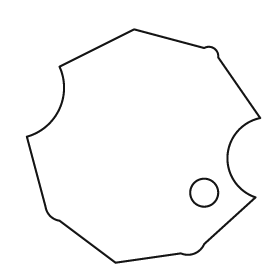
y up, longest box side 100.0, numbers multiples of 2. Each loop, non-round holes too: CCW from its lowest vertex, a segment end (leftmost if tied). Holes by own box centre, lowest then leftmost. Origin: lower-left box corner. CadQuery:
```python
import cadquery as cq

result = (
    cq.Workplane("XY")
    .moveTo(38.0, 0.0)
    .lineTo(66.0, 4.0)
    .threePointArc((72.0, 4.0), (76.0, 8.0))
    .lineTo(98.0, 28.0)
    .threePointArc((86.0, 46.0), (100.0, 62.0))
    .lineTo(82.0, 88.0)
    .threePointArc((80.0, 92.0), (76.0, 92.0))
    .lineTo(46.0, 100.0)
    .lineTo(14.0, 84.0)
    .threePointArc((14.0, 66.0), (0.0, 54.0))
    .lineTo(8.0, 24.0)
    .threePointArc((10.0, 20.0), (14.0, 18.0))
    .close()
    .moveTo(76.0, 30.0)
    .circle(6.0)
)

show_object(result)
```